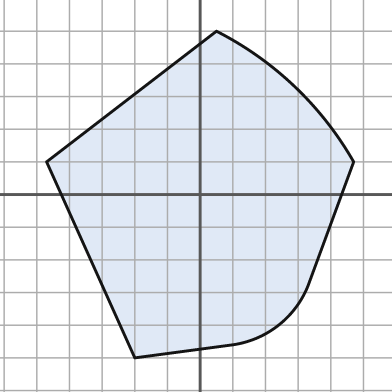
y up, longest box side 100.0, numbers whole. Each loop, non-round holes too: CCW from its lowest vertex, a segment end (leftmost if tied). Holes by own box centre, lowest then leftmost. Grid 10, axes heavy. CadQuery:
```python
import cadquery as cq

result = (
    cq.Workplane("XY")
    .moveTo(-20.0, -50.0)
    .lineTo(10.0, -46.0)
    .threePointArc((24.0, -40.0), (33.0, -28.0))
    .lineTo(47.0, 10.0)
    .threePointArc((29.0, 33.0), (5.0, 50.0))
    .lineTo(-47.0, 10.0)
    .close()
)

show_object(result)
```